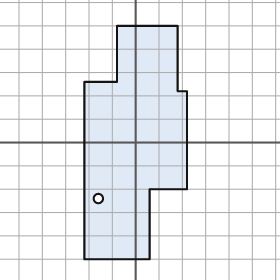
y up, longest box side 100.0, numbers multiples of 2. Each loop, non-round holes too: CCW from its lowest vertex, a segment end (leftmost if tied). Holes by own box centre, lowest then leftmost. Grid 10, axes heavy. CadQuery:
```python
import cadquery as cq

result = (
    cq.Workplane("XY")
    .moveTo(-22.0, -50.0)
    .lineTo(6.0, -50.0)
    .lineTo(6.0, -20.0)
    .lineTo(22.0, -20.0)
    .lineTo(22.0, 22.0)
    .lineTo(18.0, 22.0)
    .lineTo(18.0, 50.0)
    .lineTo(-8.0, 50.0)
    .lineTo(-8.0, 26.0)
    .lineTo(-22.0, 26.0)
    .close()
    .moveTo(-16.0, -24.0)
    .circle(2.0)
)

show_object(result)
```